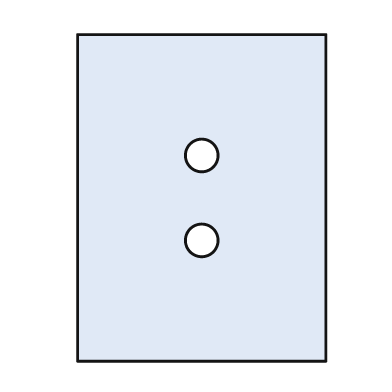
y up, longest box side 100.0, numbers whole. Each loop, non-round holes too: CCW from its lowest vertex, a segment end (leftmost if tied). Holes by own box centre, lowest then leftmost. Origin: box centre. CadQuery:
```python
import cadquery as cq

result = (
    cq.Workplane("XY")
    .moveTo(-38.0, -50.0)
    .lineTo(38.0, -50.0)
    .lineTo(38.0, 50.0)
    .lineTo(-38.0, 50.0)
    .close()
    .moveTo(0.0, -13.0)
    .circle(5.0)
    .moveTo(0.0, 13.0)
    .circle(5.0)
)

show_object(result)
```